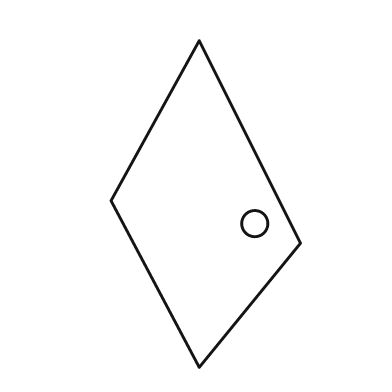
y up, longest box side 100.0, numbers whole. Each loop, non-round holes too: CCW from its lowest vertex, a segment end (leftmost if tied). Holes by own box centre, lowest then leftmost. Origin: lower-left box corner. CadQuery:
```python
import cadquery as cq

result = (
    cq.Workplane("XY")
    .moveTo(27.0, 0.0)
    .lineTo(58.0, 38.0)
    .lineTo(27.0, 100.0)
    .lineTo(0.0, 51.0)
    .close()
    .moveTo(44.0, 44.0)
    .circle(4.0)
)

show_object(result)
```